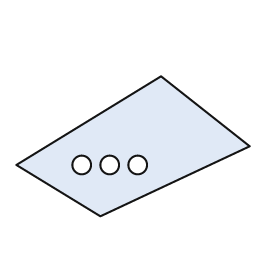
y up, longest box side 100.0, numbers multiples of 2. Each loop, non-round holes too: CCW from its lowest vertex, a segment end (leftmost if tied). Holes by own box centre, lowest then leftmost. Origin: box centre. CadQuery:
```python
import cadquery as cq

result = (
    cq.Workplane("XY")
    .moveTo(-14.0, -30.0)
    .lineTo(50.0, 0.0)
    .lineTo(12.0, 30.0)
    .lineTo(-50.0, -8.0)
    .close()
    .moveTo(-22.0, -8.0)
    .circle(4.0)
    .moveTo(-10.0, -8.0)
    .circle(4.0)
    .moveTo(2.0, -8.0)
    .circle(4.0)
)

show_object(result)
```